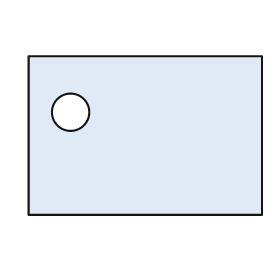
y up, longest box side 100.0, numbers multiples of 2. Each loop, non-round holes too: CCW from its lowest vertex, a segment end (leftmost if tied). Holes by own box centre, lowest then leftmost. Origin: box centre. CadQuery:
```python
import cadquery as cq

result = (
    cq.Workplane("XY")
    .moveTo(-50.0, -34.0)
    .lineTo(50.0, -34.0)
    .lineTo(50.0, 34.0)
    .lineTo(-50.0, 34.0)
    .close()
    .moveTo(-32.0, 10.0)
    .circle(8.0)
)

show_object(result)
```